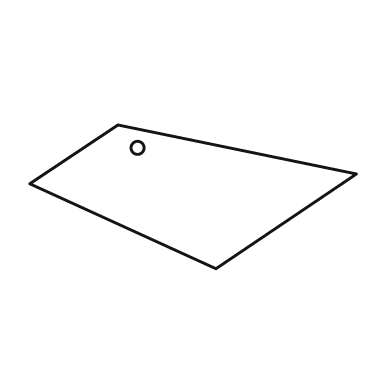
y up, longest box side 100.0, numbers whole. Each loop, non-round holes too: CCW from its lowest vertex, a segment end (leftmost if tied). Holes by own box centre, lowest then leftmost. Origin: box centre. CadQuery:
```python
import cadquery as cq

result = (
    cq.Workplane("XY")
    .moveTo(7.0, -22.0)
    .lineTo(50.0, 7.0)
    .lineTo(-23.0, 22.0)
    .lineTo(-50.0, 4.0)
    .close()
    .moveTo(-17.0, 15.0)
    .circle(2.0)
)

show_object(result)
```